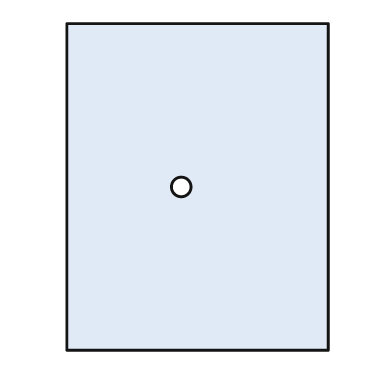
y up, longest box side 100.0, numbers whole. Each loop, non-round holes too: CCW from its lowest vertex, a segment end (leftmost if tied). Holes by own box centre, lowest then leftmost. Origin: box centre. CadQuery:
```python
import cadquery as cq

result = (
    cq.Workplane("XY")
    .moveTo(-40.0, -50.0)
    .lineTo(40.0, -50.0)
    .lineTo(40.0, 50.0)
    .lineTo(-40.0, 50.0)
    .close()
    .moveTo(-5.0, 0.0)
    .circle(3.0)
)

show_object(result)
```